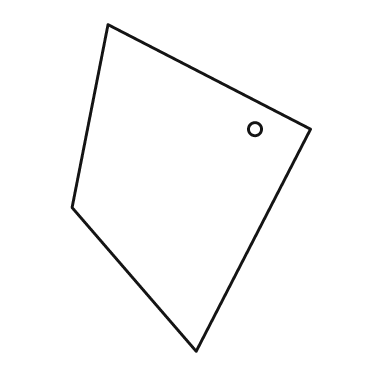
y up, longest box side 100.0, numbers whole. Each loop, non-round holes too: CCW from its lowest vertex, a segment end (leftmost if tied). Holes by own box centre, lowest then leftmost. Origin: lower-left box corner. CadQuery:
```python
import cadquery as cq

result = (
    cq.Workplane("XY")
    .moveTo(38.0, 0.0)
    .lineTo(73.0, 68.0)
    .lineTo(11.0, 100.0)
    .lineTo(0.0, 44.0)
    .close()
    .moveTo(56.0, 68.0)
    .circle(2.0)
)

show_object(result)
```